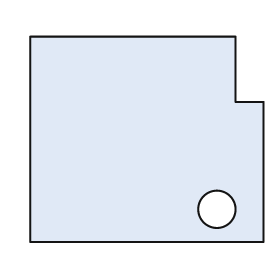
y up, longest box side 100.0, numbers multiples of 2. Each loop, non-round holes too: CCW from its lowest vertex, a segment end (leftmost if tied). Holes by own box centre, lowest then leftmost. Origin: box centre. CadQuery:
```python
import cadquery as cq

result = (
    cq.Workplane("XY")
    .moveTo(-50.0, -44.0)
    .lineTo(50.0, -44.0)
    .lineTo(50.0, 16.0)
    .lineTo(38.0, 16.0)
    .lineTo(38.0, 44.0)
    .lineTo(-50.0, 44.0)
    .close()
    .moveTo(30.0, -30.0)
    .circle(8.0)
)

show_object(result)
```